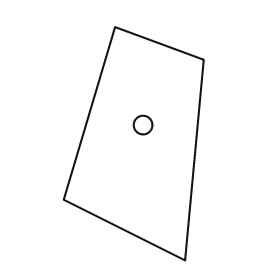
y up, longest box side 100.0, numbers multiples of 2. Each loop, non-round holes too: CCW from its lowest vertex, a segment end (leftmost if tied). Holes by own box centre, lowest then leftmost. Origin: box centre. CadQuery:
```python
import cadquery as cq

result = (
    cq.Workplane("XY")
    .moveTo(22.0, -50.0)
    .lineTo(30.0, 36.0)
    .lineTo(-8.0, 50.0)
    .lineTo(-30.0, -24.0)
    .close()
    .moveTo(4.0, 8.0)
    .circle(4.0)
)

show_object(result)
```